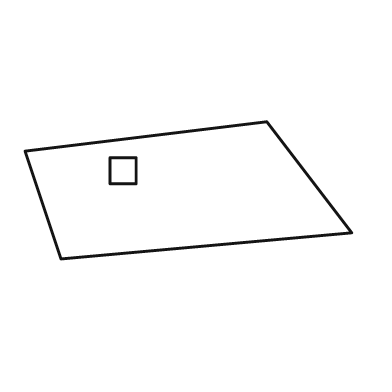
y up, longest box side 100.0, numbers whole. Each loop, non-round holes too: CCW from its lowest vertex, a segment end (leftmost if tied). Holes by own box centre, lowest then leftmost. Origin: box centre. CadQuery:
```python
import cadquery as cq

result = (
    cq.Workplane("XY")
    .moveTo(-39.0, -21.0)
    .lineTo(50.0, -13.0)
    .lineTo(24.0, 21.0)
    .lineTo(-50.0, 12.0)
    .close()
    .moveTo(-24.0, 2.0)
    .lineTo(-16.0, 2.0)
    .lineTo(-16.0, 10.0)
    .lineTo(-24.0, 10.0)
    .close()
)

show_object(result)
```